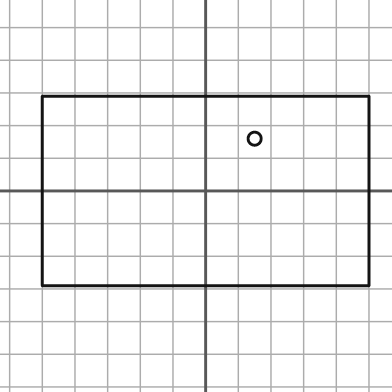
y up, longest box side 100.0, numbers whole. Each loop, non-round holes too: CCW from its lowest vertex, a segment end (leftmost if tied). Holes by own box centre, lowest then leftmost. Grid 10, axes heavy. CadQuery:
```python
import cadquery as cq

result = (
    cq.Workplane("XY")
    .moveTo(-50.0, -29.0)
    .lineTo(50.0, -29.0)
    .lineTo(50.0, 29.0)
    .lineTo(-50.0, 29.0)
    .close()
    .moveTo(15.0, 16.0)
    .circle(2.0)
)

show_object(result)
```